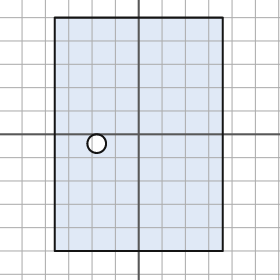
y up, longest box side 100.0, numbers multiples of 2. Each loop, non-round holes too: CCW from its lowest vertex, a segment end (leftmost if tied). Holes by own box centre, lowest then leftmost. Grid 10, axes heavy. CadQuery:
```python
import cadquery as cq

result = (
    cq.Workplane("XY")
    .moveTo(-36.0, -50.0)
    .lineTo(36.0, -50.0)
    .lineTo(36.0, 50.0)
    .lineTo(-36.0, 50.0)
    .close()
    .moveTo(-18.0, -4.0)
    .circle(4.0)
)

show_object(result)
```